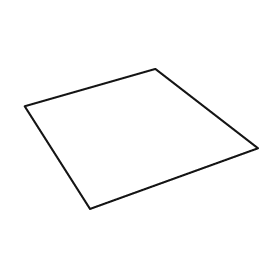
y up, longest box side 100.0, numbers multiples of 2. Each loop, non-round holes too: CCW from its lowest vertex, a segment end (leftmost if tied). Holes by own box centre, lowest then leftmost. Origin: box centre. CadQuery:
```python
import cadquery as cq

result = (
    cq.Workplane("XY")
    .moveTo(-22.0, -30.0)
    .lineTo(50.0, -4.0)
    .lineTo(6.0, 30.0)
    .lineTo(-50.0, 14.0)
    .close()
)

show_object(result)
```